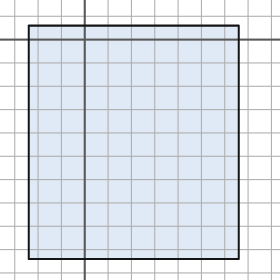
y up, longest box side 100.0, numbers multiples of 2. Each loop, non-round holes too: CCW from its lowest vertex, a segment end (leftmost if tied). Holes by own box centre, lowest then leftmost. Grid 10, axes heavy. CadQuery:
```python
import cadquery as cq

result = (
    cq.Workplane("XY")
    .moveTo(-24.0, -94.0)
    .lineTo(66.0, -94.0)
    .lineTo(66.0, 6.0)
    .lineTo(-24.0, 6.0)
    .close()
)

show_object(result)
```